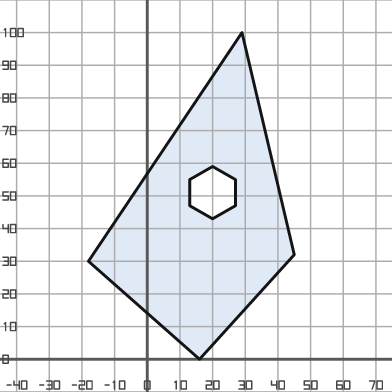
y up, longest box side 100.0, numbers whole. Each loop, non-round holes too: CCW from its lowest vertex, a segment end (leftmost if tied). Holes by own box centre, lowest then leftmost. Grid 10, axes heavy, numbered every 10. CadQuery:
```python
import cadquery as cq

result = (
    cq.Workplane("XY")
    .moveTo(16.0, 0.0)
    .lineTo(45.0, 32.0)
    .lineTo(29.0, 100.0)
    .lineTo(-18.0, 30.0)
    .close()
    .moveTo(20.0, 43.0)
    .lineTo(27.0, 47.0)
    .lineTo(27.0, 55.0)
    .lineTo(20.0, 59.0)
    .lineTo(13.0, 55.0)
    .lineTo(13.0, 47.0)
    .close()
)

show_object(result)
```